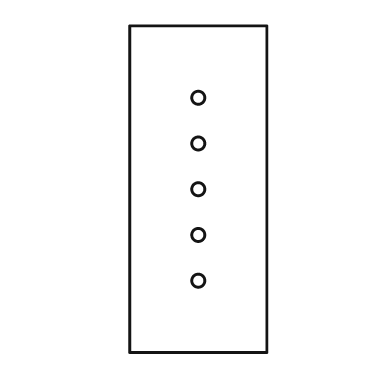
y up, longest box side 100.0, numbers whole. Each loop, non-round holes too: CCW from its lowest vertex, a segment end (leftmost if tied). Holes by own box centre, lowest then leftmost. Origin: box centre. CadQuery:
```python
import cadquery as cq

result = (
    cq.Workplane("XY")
    .moveTo(-21.0, -50.0)
    .lineTo(21.0, -50.0)
    .lineTo(21.0, 50.0)
    .lineTo(-21.0, 50.0)
    .close()
    .moveTo(0.0, -28.0)
    .circle(2.0)
    .moveTo(0.0, -14.0)
    .circle(2.0)
    .moveTo(0.0, 0.0)
    .circle(2.0)
    .moveTo(0.0, 14.0)
    .circle(2.0)
    .moveTo(0.0, 28.0)
    .circle(2.0)
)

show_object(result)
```